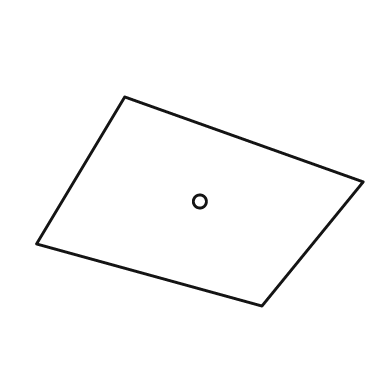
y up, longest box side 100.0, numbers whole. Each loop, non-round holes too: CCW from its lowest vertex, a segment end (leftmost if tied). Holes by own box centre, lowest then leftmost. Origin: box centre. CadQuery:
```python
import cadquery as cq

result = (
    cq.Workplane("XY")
    .moveTo(19.0, -32.0)
    .lineTo(50.0, 6.0)
    .lineTo(-23.0, 32.0)
    .lineTo(-50.0, -13.0)
    .close()
    .moveTo(0.0, 0.0)
    .circle(2.0)
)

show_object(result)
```